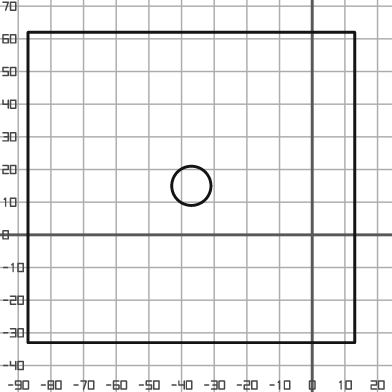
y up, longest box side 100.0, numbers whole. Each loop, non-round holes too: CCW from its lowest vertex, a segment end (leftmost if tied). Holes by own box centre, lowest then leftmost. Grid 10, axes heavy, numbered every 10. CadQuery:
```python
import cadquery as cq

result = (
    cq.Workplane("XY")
    .moveTo(-87.0, -33.0)
    .lineTo(13.0, -33.0)
    .lineTo(13.0, 62.0)
    .lineTo(-87.0, 62.0)
    .close()
    .moveTo(-37.0, 15.0)
    .circle(6.0)
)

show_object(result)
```